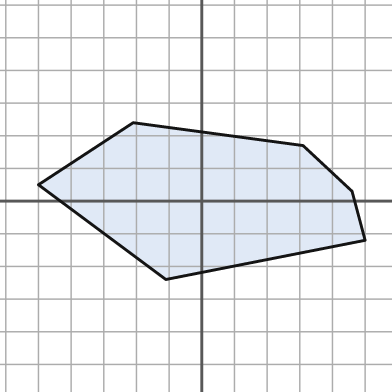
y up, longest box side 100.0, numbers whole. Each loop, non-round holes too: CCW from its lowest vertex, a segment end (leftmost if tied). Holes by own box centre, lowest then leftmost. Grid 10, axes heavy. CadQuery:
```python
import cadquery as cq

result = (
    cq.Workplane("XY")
    .moveTo(-11.0, -24.0)
    .lineTo(50.0, -12.0)
    .lineTo(46.0, 3.0)
    .lineTo(31.0, 17.0)
    .lineTo(-21.0, 24.0)
    .lineTo(-50.0, 5.0)
    .close()
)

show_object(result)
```